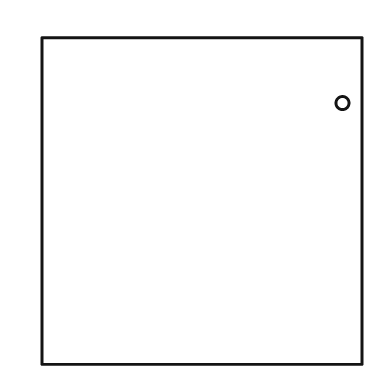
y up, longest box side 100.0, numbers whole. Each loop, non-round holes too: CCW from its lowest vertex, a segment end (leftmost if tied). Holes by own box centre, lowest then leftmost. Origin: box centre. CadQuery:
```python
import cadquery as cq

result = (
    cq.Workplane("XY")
    .moveTo(-49.0, -50.0)
    .lineTo(49.0, -50.0)
    .lineTo(49.0, 50.0)
    .lineTo(-49.0, 50.0)
    .close()
    .moveTo(43.0, 30.0)
    .circle(2.0)
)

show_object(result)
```